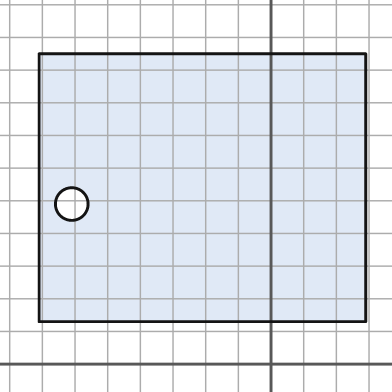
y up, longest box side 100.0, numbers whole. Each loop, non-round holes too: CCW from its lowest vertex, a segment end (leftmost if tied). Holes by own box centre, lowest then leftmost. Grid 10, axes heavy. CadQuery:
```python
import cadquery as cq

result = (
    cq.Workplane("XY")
    .moveTo(-71.0, 13.0)
    .lineTo(29.0, 13.0)
    .lineTo(29.0, 95.0)
    .lineTo(-71.0, 95.0)
    .close()
    .moveTo(-61.0, 49.0)
    .circle(5.0)
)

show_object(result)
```